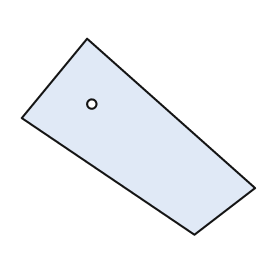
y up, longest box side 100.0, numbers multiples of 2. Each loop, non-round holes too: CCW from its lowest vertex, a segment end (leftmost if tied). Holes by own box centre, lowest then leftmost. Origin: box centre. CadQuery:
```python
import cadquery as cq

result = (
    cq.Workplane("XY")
    .moveTo(24.0, -42.0)
    .lineTo(50.0, -22.0)
    .lineTo(-22.0, 42.0)
    .lineTo(-50.0, 8.0)
    .close()
    .moveTo(-20.0, 14.0)
    .circle(2.0)
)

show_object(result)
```